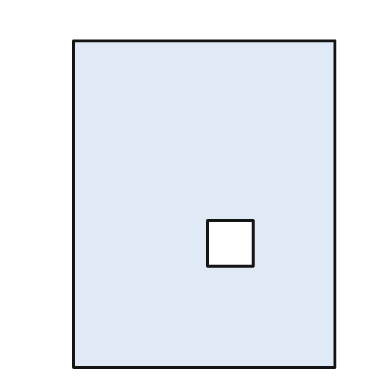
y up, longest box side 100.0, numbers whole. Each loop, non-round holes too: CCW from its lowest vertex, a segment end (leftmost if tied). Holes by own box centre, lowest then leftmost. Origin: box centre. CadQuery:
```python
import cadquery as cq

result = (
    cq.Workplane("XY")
    .moveTo(-40.0, -50.0)
    .lineTo(40.0, -50.0)
    .lineTo(40.0, 50.0)
    .lineTo(-40.0, 50.0)
    .close()
    .moveTo(1.0, -19.0)
    .lineTo(15.0, -19.0)
    .lineTo(15.0, -5.0)
    .lineTo(1.0, -5.0)
    .close()
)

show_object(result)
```